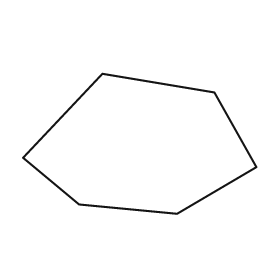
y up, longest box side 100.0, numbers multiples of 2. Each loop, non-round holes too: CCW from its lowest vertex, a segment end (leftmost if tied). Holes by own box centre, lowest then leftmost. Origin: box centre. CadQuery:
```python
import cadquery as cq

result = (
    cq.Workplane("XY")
    .moveTo(16.0, -30.0)
    .lineTo(50.0, -10.0)
    .lineTo(32.0, 22.0)
    .lineTo(-16.0, 30.0)
    .lineTo(-50.0, -6.0)
    .lineTo(-26.0, -26.0)
    .close()
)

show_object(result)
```